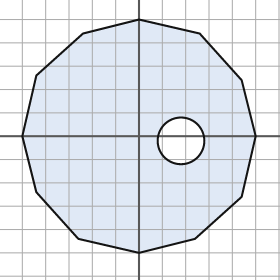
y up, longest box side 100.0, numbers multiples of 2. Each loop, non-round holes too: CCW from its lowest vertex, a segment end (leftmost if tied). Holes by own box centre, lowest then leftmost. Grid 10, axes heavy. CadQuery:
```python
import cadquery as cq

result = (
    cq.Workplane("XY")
    .moveTo(0.0, -50.0)
    .lineTo(24.0, -44.0)
    .lineTo(44.0, -26.0)
    .lineTo(50.0, 0.0)
    .lineTo(44.0, 24.0)
    .lineTo(26.0, 44.0)
    .lineTo(0.0, 50.0)
    .lineTo(-24.0, 44.0)
    .lineTo(-44.0, 26.0)
    .lineTo(-50.0, 0.0)
    .lineTo(-44.0, -24.0)
    .lineTo(-26.0, -44.0)
    .close()
    .moveTo(18.0, -2.0)
    .circle(10.0)
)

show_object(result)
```